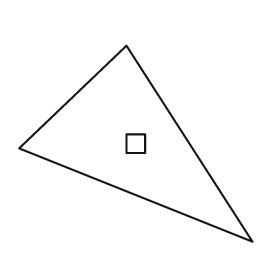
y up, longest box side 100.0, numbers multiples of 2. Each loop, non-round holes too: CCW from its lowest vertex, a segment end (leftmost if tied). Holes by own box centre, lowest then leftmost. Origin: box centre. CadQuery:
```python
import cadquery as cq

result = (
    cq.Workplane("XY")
    .moveTo(50.0, -42.0)
    .lineTo(-4.0, 42.0)
    .lineTo(-50.0, -2.0)
    .close()
    .moveTo(-4.0, -4.0)
    .lineTo(4.0, -4.0)
    .lineTo(4.0, 4.0)
    .lineTo(-4.0, 4.0)
    .close()
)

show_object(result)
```